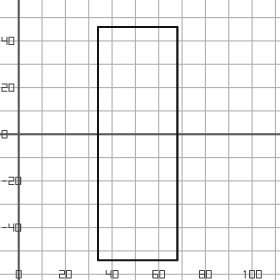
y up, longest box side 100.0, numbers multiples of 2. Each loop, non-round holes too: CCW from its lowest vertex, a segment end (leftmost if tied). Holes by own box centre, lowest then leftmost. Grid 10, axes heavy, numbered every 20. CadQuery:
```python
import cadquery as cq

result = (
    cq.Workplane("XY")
    .moveTo(34.0, -54.0)
    .lineTo(68.0, -54.0)
    .lineTo(68.0, 46.0)
    .lineTo(34.0, 46.0)
    .close()
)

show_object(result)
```